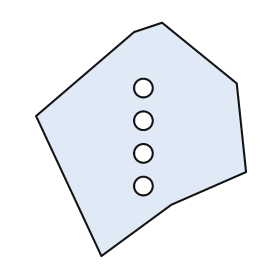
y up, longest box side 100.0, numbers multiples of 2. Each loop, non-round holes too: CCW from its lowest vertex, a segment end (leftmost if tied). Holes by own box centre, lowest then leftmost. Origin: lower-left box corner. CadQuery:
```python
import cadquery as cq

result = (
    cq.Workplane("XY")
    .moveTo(28.0, 0.0)
    .lineTo(58.0, 22.0)
    .lineTo(90.0, 36.0)
    .lineTo(86.0, 74.0)
    .lineTo(54.0, 100.0)
    .lineTo(42.0, 96.0)
    .lineTo(0.0, 60.0)
    .close()
    .moveTo(46.0, 30.0)
    .circle(4.0)
    .moveTo(46.0, 44.0)
    .circle(4.0)
    .moveTo(46.0, 58.0)
    .circle(4.0)
    .moveTo(46.0, 72.0)
    .circle(4.0)
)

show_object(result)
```